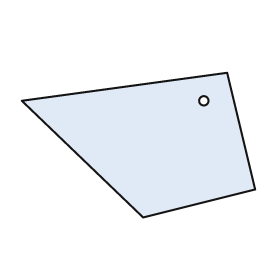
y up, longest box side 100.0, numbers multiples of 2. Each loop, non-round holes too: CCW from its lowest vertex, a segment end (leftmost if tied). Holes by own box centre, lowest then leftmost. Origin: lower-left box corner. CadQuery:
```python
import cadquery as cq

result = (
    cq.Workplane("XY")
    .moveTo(52.0, 0.0)
    .lineTo(100.0, 12.0)
    .lineTo(88.0, 62.0)
    .lineTo(0.0, 50.0)
    .close()
    .moveTo(78.0, 50.0)
    .circle(2.0)
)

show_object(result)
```